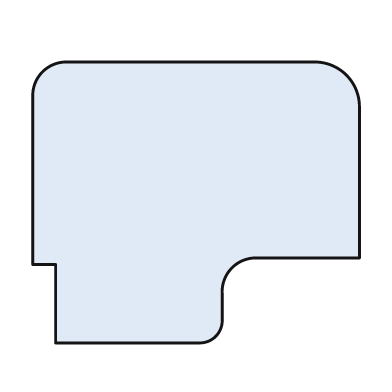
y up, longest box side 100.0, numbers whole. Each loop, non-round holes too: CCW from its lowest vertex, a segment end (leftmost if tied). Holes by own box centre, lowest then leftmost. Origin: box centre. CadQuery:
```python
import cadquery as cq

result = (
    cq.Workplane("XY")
    .moveTo(-43.0, -43.0)
    .lineTo(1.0, -43.0)
    .threePointArc((6.0, -41.0), (8.0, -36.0))
    .lineTo(8.0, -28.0)
    .threePointArc((11.0, -20.0), (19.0, -17.0))
    .lineTo(50.0, -17.0)
    .lineTo(50.0, 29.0)
    .threePointArc((46.0, 39.0), (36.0, 43.0))
    .lineTo(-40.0, 43.0)
    .threePointArc((-47.0, 40.0), (-50.0, 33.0))
    .lineTo(-50.0, -19.0)
    .lineTo(-43.0, -19.0)
    .close()
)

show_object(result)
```